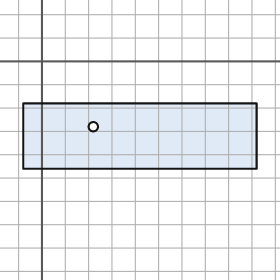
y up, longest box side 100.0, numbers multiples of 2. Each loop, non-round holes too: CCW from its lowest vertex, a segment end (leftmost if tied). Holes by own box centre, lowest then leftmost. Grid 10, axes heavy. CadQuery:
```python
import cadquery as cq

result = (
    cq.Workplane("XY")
    .moveTo(-8.0, -46.0)
    .lineTo(92.0, -46.0)
    .lineTo(92.0, -18.0)
    .lineTo(-8.0, -18.0)
    .close()
    .moveTo(22.0, -28.0)
    .circle(2.0)
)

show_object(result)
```